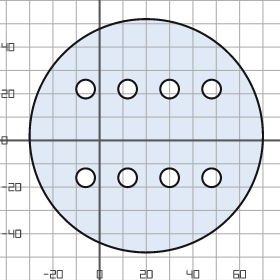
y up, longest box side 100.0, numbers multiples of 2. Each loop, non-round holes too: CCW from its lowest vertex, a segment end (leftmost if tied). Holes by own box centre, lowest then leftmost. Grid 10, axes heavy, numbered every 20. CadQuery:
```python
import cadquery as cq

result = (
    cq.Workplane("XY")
    .moveTo(20.0, 2.0)
    .circle(50.0)
    .moveTo(-6.0, -16.0)
    .circle(4.0)
    .moveTo(12.0, -16.0)
    .circle(4.0)
    .moveTo(30.0, -16.0)
    .circle(4.0)
    .moveTo(48.0, -16.0)
    .circle(4.0)
    .moveTo(-6.0, 22.0)
    .circle(4.0)
    .moveTo(12.0, 22.0)
    .circle(4.0)
    .moveTo(30.0, 22.0)
    .circle(4.0)
    .moveTo(48.0, 22.0)
    .circle(4.0)
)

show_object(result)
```